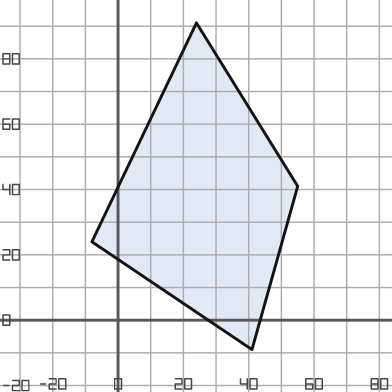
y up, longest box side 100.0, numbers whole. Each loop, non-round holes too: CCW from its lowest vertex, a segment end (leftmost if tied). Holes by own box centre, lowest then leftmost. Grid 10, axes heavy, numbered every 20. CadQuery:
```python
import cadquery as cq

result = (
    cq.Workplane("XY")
    .moveTo(41.0, -9.0)
    .lineTo(55.0, 41.0)
    .lineTo(24.0, 91.0)
    .lineTo(-8.0, 24.0)
    .close()
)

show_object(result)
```